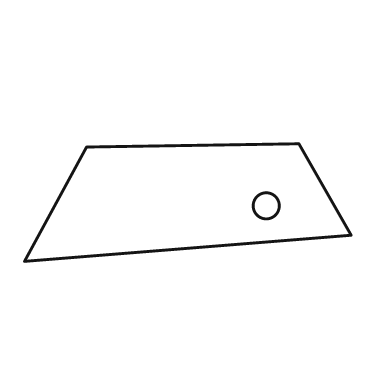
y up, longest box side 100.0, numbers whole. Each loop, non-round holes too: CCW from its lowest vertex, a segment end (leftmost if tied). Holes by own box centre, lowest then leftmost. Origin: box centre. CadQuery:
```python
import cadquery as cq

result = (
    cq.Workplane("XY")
    .moveTo(-50.0, -18.0)
    .lineTo(50.0, -10.0)
    .lineTo(34.0, 18.0)
    .lineTo(-31.0, 17.0)
    .close()
    .moveTo(24.0, -1.0)
    .circle(4.0)
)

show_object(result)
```